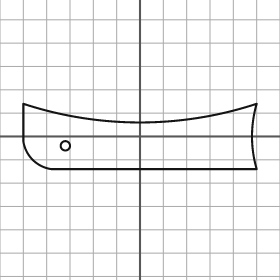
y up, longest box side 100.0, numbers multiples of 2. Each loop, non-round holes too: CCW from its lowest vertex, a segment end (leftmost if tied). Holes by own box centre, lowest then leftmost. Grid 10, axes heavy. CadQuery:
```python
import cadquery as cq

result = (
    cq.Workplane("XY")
    .moveTo(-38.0, -14.0)
    .lineTo(50.0, -14.0)
    .threePointArc((48.0, 0.0), (50.0, 14.0))
    .threePointArc((0.0, 6.0), (-50.0, 14.0))
    .lineTo(-50.0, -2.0)
    .threePointArc((-46.0, -10.0), (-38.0, -14.0))
    .close()
    .moveTo(-32.0, -4.0)
    .circle(2.0)
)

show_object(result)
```